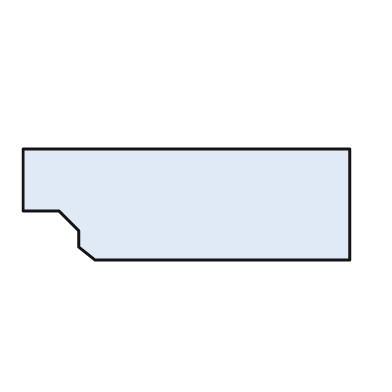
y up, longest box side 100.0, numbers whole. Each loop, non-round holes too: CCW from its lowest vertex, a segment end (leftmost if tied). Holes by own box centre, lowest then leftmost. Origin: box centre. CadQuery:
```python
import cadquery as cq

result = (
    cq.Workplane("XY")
    .moveTo(-28.0, -17.0)
    .lineTo(50.0, -17.0)
    .lineTo(50.0, 17.0)
    .lineTo(-50.0, 17.0)
    .lineTo(-50.0, -2.0)
    .lineTo(-39.0, -2.0)
    .lineTo(-33.0, -8.0)
    .lineTo(-33.0, -13.0)
    .close()
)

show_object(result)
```